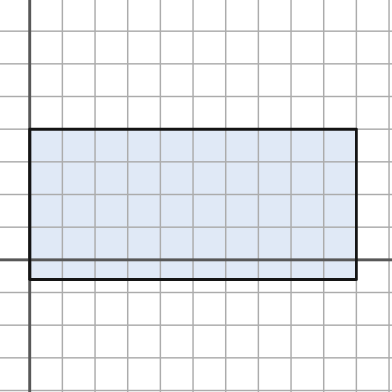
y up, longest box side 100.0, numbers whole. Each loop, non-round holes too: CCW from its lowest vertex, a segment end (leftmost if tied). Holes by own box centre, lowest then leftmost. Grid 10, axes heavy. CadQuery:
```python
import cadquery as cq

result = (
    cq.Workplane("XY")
    .moveTo(0.0, -6.0)
    .lineTo(100.0, -6.0)
    .lineTo(100.0, 40.0)
    .lineTo(0.0, 40.0)
    .close()
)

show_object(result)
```